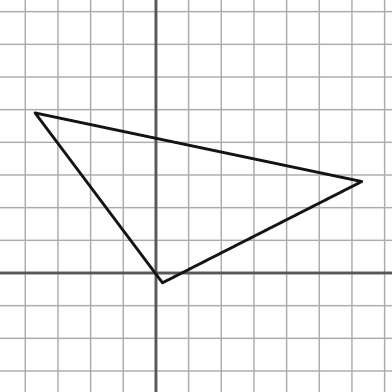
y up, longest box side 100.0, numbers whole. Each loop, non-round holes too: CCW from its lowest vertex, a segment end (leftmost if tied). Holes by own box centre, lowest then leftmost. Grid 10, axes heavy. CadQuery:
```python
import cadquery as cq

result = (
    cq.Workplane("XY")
    .moveTo(2.0, -3.0)
    .lineTo(63.0, 28.0)
    .lineTo(-37.0, 49.0)
    .close()
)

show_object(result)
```